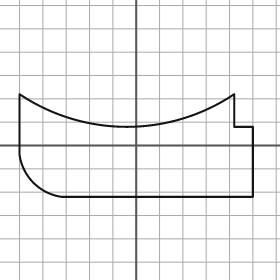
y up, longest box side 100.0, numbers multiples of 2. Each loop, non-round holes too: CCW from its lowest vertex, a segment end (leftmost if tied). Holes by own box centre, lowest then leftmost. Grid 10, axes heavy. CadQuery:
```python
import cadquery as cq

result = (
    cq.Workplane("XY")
    .moveTo(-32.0, -22.0)
    .lineTo(50.0, -22.0)
    .lineTo(50.0, 8.0)
    .lineTo(42.0, 8.0)
    .lineTo(42.0, 22.0)
    .threePointArc((-4.0, 8.0), (-50.0, 22.0))
    .lineTo(-50.0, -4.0)
    .threePointArc((-44.0, -16.0), (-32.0, -22.0))
    .close()
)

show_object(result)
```